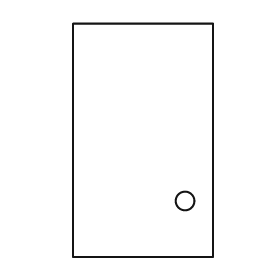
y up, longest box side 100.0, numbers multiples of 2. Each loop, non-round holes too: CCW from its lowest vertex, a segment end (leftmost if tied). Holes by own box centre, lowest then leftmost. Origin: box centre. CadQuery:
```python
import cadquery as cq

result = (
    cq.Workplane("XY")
    .moveTo(-30.0, -50.0)
    .lineTo(30.0, -50.0)
    .lineTo(30.0, 50.0)
    .lineTo(-30.0, 50.0)
    .close()
    .moveTo(18.0, -26.0)
    .circle(4.0)
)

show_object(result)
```